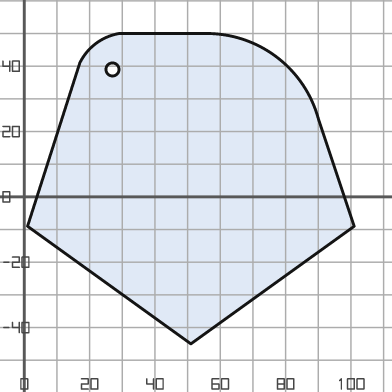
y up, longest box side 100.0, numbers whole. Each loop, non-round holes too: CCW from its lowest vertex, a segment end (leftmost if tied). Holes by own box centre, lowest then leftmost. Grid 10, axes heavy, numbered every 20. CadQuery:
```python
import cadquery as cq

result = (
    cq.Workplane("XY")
    .moveTo(51.0, -45.0)
    .lineTo(101.0, -9.0)
    .lineTo(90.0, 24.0)
    .threePointArc((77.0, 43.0), (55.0, 50.0))
    .lineTo(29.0, 50.0)
    .threePointArc((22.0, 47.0), (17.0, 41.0))
    .lineTo(1.0, -9.0)
    .close()
    .moveTo(27.0, 39.0)
    .circle(2.0)
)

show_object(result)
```